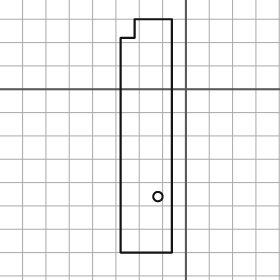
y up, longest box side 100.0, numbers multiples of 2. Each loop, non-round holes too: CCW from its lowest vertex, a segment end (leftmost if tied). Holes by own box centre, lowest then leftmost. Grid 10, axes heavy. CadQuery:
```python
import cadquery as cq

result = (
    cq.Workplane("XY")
    .moveTo(-28.0, -70.0)
    .lineTo(-6.0, -70.0)
    .lineTo(-6.0, 30.0)
    .lineTo(-22.0, 30.0)
    .lineTo(-22.0, 22.0)
    .lineTo(-28.0, 22.0)
    .close()
    .moveTo(-12.0, -46.0)
    .circle(2.0)
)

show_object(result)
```